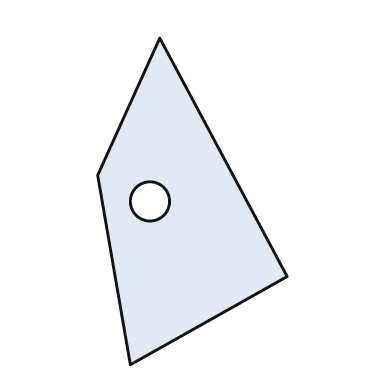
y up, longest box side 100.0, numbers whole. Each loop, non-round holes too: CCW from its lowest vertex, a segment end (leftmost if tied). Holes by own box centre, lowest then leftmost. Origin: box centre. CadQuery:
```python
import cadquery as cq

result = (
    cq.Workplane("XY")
    .moveTo(-19.0, -50.0)
    .lineTo(29.0, -23.0)
    .lineTo(-10.0, 50.0)
    .lineTo(-29.0, 8.0)
    .close()
    .moveTo(-13.0, 0.0)
    .circle(6.0)
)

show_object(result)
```